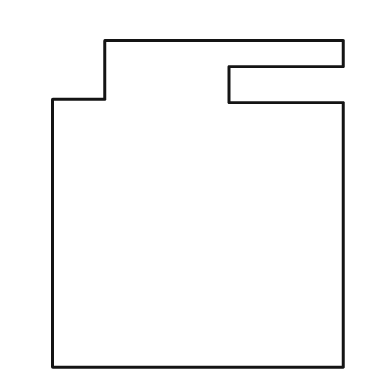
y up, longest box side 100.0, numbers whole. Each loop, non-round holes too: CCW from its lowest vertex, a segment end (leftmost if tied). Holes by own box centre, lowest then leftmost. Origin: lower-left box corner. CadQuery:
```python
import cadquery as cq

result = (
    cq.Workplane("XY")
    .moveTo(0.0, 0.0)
    .lineTo(89.0, 0.0)
    .lineTo(89.0, 81.0)
    .lineTo(54.0, 81.0)
    .lineTo(54.0, 92.0)
    .lineTo(89.0, 92.0)
    .lineTo(89.0, 100.0)
    .lineTo(16.0, 100.0)
    .lineTo(16.0, 82.0)
    .lineTo(0.0, 82.0)
    .close()
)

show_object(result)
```